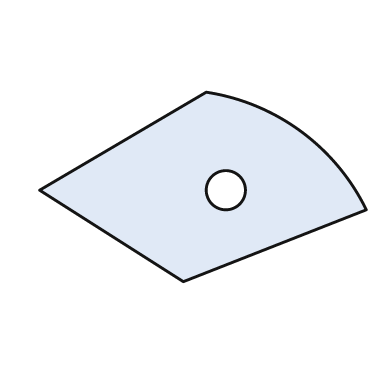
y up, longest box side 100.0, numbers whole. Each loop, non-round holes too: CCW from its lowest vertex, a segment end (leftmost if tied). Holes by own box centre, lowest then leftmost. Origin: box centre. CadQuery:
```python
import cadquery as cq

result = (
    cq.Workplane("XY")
    .moveTo(-6.0, -29.0)
    .lineTo(50.0, -7.0)
    .threePointArc((30.0, 17.0), (1.0, 29.0))
    .lineTo(-50.0, -1.0)
    .close()
    .moveTo(7.0, -1.0)
    .circle(6.0)
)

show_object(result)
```